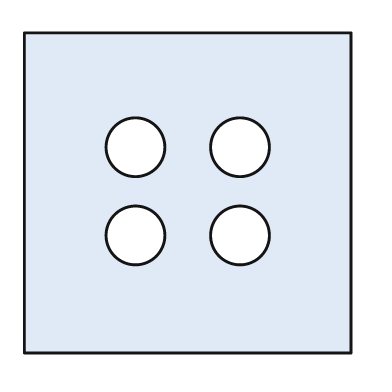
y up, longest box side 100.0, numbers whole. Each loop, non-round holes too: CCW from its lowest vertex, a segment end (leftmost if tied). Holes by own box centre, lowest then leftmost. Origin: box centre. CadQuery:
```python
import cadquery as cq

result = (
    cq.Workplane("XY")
    .moveTo(-50.0, -49.0)
    .lineTo(50.0, -49.0)
    .lineTo(50.0, 49.0)
    .lineTo(-50.0, 49.0)
    .close()
    .moveTo(-16.0, -13.0)
    .circle(9.0)
    .moveTo(16.0, -13.0)
    .circle(9.0)
    .moveTo(-16.0, 14.0)
    .circle(9.0)
    .moveTo(16.0, 14.0)
    .circle(9.0)
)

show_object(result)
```